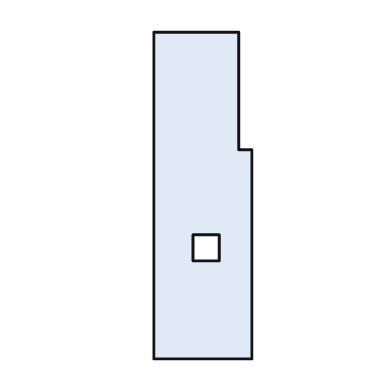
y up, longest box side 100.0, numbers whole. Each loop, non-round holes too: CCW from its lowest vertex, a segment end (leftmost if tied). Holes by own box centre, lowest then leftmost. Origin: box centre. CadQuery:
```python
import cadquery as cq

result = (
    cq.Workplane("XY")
    .moveTo(-15.0, -50.0)
    .lineTo(15.0, -50.0)
    .lineTo(15.0, 14.0)
    .lineTo(11.0, 14.0)
    .lineTo(11.0, 50.0)
    .lineTo(-15.0, 50.0)
    .close()
    .moveTo(-3.0, -20.0)
    .lineTo(5.0, -20.0)
    .lineTo(5.0, -12.0)
    .lineTo(-3.0, -12.0)
    .close()
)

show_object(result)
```